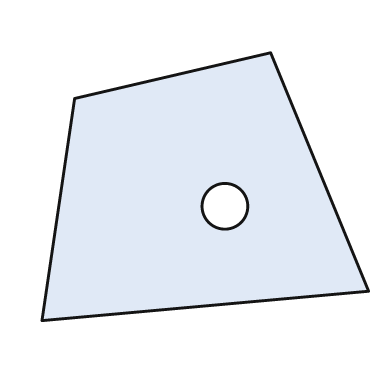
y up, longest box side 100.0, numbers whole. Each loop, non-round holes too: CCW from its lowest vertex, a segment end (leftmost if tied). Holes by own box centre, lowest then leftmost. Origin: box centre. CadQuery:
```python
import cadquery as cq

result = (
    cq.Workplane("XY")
    .moveTo(-50.0, -41.0)
    .lineTo(50.0, -32.0)
    .lineTo(20.0, 41.0)
    .lineTo(-40.0, 27.0)
    .close()
    .moveTo(6.0, -6.0)
    .circle(7.0)
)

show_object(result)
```